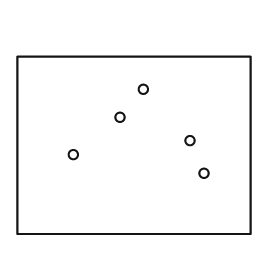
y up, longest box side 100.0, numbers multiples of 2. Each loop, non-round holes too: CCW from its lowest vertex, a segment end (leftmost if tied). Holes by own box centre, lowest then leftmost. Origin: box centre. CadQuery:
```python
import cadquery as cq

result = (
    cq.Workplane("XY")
    .moveTo(-50.0, -38.0)
    .lineTo(50.0, -38.0)
    .lineTo(50.0, 38.0)
    .lineTo(-50.0, 38.0)
    .close()
    .moveTo(30.0, -12.0)
    .circle(2.0)
    .moveTo(-26.0, -4.0)
    .circle(2.0)
    .moveTo(24.0, 2.0)
    .circle(2.0)
    .moveTo(-6.0, 12.0)
    .circle(2.0)
    .moveTo(4.0, 24.0)
    .circle(2.0)
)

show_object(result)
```